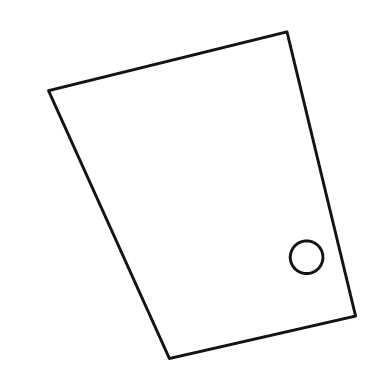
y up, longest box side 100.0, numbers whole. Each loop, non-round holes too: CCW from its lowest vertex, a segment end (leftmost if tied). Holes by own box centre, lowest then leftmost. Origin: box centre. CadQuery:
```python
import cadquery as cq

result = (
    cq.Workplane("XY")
    .moveTo(-10.0, -50.0)
    .lineTo(47.0, -37.0)
    .lineTo(26.0, 50.0)
    .lineTo(-47.0, 32.0)
    .close()
    .moveTo(32.0, -19.0)
    .circle(5.0)
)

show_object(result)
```